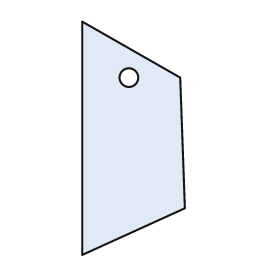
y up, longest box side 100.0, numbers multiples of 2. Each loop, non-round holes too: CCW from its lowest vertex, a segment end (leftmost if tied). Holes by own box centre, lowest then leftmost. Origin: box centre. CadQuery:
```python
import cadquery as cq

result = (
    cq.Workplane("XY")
    .moveTo(-22.0, -50.0)
    .lineTo(22.0, -30.0)
    .lineTo(20.0, 26.0)
    .lineTo(-22.0, 50.0)
    .close()
    .moveTo(-2.0, 26.0)
    .circle(4.0)
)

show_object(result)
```